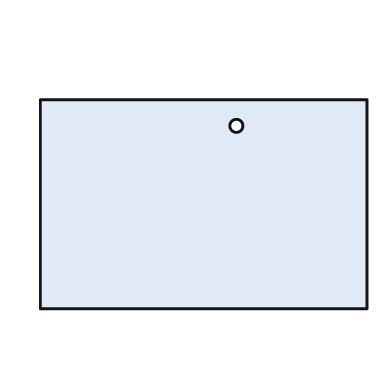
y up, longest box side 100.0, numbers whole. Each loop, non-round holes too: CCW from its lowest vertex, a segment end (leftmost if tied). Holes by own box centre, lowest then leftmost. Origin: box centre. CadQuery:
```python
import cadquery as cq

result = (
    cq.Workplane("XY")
    .moveTo(-50.0, -32.0)
    .lineTo(50.0, -32.0)
    .lineTo(50.0, 32.0)
    .lineTo(-50.0, 32.0)
    .close()
    .moveTo(10.0, 24.0)
    .circle(2.0)
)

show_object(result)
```